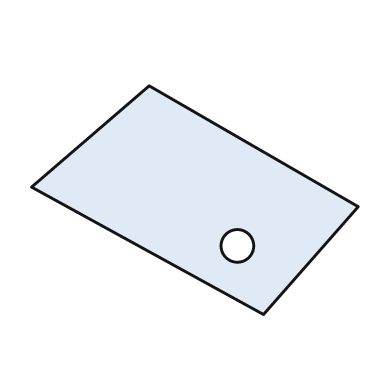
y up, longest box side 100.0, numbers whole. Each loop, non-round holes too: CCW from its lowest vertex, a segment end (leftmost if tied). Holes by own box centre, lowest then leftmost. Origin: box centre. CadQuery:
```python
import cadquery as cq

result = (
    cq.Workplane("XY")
    .moveTo(21.0, -35.0)
    .lineTo(50.0, -2.0)
    .lineTo(-14.0, 35.0)
    .lineTo(-50.0, 4.0)
    .close()
    .moveTo(13.0, -14.0)
    .circle(5.0)
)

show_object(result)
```